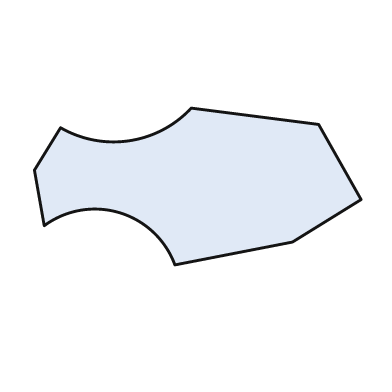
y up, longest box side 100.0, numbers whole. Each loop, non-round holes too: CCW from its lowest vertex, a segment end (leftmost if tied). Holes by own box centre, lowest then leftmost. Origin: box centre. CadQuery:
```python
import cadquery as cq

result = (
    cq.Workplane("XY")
    .moveTo(-7.0, -24.0)
    .lineTo(29.0, -17.0)
    .lineTo(50.0, -4.0)
    .lineTo(37.0, 19.0)
    .lineTo(-2.0, 24.0)
    .threePointArc((-21.0, 14.0), (-42.0, 18.0))
    .lineTo(-50.0, 5.0)
    .lineTo(-47.0, -12.0)
    .threePointArc((-24.0, -8.0), (-7.0, -24.0))
    .close()
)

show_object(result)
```